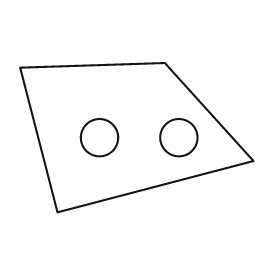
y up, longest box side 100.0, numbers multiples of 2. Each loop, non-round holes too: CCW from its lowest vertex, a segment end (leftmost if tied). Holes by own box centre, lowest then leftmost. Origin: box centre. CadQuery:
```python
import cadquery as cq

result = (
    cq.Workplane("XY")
    .moveTo(-34.0, -32.0)
    .lineTo(50.0, -10.0)
    .lineTo(12.0, 32.0)
    .lineTo(-50.0, 30.0)
    .close()
    .moveTo(-16.0, 0.0)
    .circle(8.0)
    .moveTo(18.0, 0.0)
    .circle(8.0)
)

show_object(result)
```